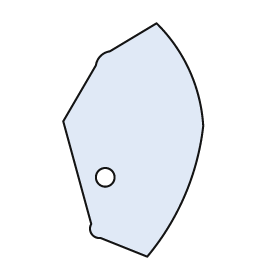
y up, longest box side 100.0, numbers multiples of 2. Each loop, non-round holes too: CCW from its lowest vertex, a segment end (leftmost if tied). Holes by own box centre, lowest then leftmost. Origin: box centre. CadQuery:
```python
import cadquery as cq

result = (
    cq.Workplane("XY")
    .moveTo(6.0, -50.0)
    .threePointArc((22.0, -24.0), (30.0, 6.0))
    .threePointArc((24.0, 30.0), (10.0, 50.0))
    .lineTo(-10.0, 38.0)
    .threePointArc((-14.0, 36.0), (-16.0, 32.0))
    .lineTo(-30.0, 8.0)
    .lineTo(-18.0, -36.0)
    .threePointArc((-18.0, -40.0), (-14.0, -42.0))
    .close()
    .moveTo(-12.0, -16.0)
    .circle(4.0)
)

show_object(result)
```